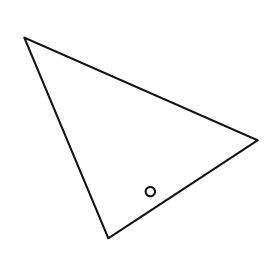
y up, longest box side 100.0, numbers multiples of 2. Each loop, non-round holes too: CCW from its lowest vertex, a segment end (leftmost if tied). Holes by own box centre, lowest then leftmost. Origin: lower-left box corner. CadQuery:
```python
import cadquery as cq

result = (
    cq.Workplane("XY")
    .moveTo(36.0, 0.0)
    .lineTo(100.0, 42.0)
    .lineTo(0.0, 86.0)
    .close()
    .moveTo(54.0, 20.0)
    .circle(2.0)
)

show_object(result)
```